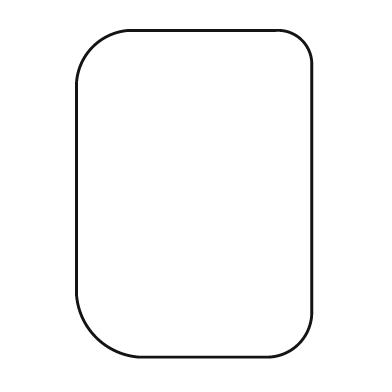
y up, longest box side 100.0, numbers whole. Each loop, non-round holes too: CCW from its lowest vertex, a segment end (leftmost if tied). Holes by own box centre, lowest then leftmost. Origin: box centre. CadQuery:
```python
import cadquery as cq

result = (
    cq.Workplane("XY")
    .moveTo(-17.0, -50.0)
    .lineTo(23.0, -50.0)
    .threePointArc((32.0, -46.0), (36.0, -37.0))
    .lineTo(36.0, 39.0)
    .threePointArc((33.0, 47.0), (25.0, 50.0))
    .lineTo(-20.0, 50.0)
    .threePointArc((-31.0, 45.0), (-36.0, 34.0))
    .lineTo(-36.0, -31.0)
    .threePointArc((-30.0, -44.0), (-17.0, -50.0))
    .close()
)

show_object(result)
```